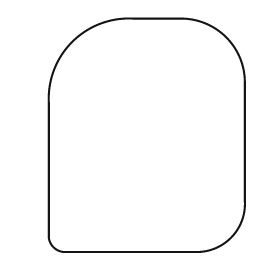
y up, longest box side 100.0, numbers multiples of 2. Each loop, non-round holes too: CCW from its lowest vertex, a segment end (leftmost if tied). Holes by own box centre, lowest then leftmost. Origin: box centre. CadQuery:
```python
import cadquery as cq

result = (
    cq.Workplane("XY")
    .moveTo(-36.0, -50.0)
    .lineTo(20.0, -50.0)
    .threePointArc((36.0, -44.0), (42.0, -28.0))
    .lineTo(42.0, 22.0)
    .threePointArc((34.0, 42.0), (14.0, 50.0))
    .lineTo(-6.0, 50.0)
    .threePointArc((-32.0, 40.0), (-42.0, 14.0))
    .lineTo(-42.0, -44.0)
    .threePointArc((-40.0, -48.0), (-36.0, -50.0))
    .close()
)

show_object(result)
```